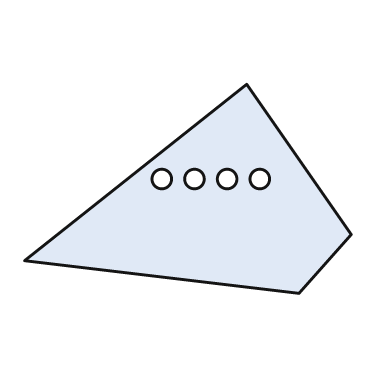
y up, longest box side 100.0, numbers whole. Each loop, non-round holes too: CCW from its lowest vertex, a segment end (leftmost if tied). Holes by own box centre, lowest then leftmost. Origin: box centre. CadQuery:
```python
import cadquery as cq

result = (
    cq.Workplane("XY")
    .moveTo(34.0, -32.0)
    .lineTo(50.0, -14.0)
    .lineTo(18.0, 32.0)
    .lineTo(-50.0, -22.0)
    .close()
    .moveTo(-8.0, 3.0)
    .circle(3.0)
    .moveTo(2.0, 3.0)
    .circle(3.0)
    .moveTo(12.0, 3.0)
    .circle(3.0)
    .moveTo(22.0, 3.0)
    .circle(3.0)
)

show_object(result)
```